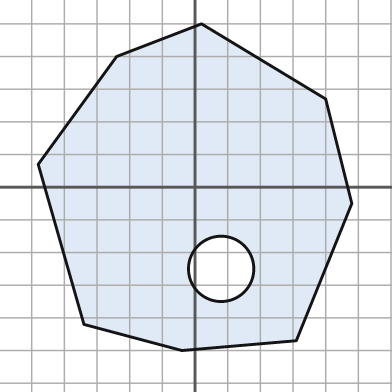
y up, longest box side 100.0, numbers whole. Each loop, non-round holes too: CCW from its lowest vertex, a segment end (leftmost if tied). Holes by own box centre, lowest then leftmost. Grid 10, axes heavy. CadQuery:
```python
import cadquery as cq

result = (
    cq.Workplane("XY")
    .moveTo(-4.0, -50.0)
    .lineTo(31.0, -47.0)
    .lineTo(48.0, -5.0)
    .lineTo(40.0, 27.0)
    .lineTo(2.0, 50.0)
    .lineTo(-24.0, 40.0)
    .lineTo(-48.0, 7.0)
    .lineTo(-34.0, -42.0)
    .close()
    .moveTo(8.0, -25.0)
    .circle(10.0)
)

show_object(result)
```